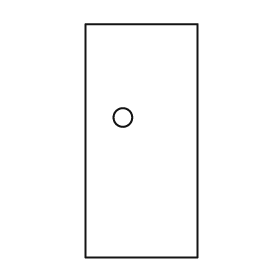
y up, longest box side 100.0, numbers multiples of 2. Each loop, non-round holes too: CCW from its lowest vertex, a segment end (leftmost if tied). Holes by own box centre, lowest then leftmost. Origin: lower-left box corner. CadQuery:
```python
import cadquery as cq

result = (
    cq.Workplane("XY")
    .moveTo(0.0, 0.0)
    .lineTo(48.0, 0.0)
    .lineTo(48.0, 100.0)
    .lineTo(0.0, 100.0)
    .close()
    .moveTo(16.0, 60.0)
    .circle(4.0)
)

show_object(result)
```